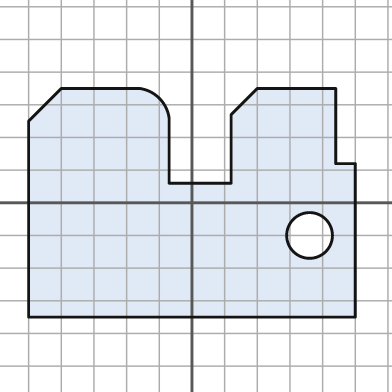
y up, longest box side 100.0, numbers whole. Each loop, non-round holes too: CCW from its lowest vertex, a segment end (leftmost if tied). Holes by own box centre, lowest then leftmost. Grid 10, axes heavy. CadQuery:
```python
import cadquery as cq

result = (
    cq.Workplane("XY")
    .moveTo(-50.0, -35.0)
    .lineTo(50.0, -35.0)
    .lineTo(50.0, 12.0)
    .lineTo(44.0, 12.0)
    .lineTo(44.0, 35.0)
    .lineTo(20.0, 35.0)
    .lineTo(12.0, 27.0)
    .lineTo(12.0, 6.0)
    .lineTo(-7.0, 6.0)
    .lineTo(-7.0, 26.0)
    .threePointArc((-10.0, 32.0), (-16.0, 35.0))
    .lineTo(-40.0, 35.0)
    .lineTo(-50.0, 25.0)
    .close()
    .moveTo(36.0, -10.0)
    .circle(7.0)
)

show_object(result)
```